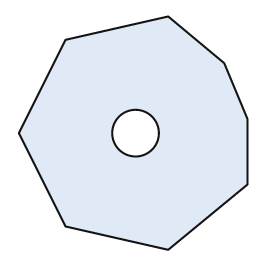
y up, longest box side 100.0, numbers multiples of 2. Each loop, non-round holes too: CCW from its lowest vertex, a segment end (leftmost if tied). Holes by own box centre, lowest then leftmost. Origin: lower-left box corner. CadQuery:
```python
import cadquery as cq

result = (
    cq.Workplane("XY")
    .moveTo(64.0, 0.0)
    .lineTo(98.0, 28.0)
    .lineTo(98.0, 56.0)
    .lineTo(88.0, 80.0)
    .lineTo(64.0, 100.0)
    .lineTo(20.0, 90.0)
    .lineTo(0.0, 50.0)
    .lineTo(20.0, 10.0)
    .close()
    .moveTo(50.0, 50.0)
    .circle(10.0)
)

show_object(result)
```